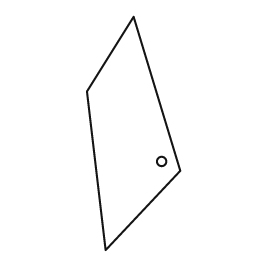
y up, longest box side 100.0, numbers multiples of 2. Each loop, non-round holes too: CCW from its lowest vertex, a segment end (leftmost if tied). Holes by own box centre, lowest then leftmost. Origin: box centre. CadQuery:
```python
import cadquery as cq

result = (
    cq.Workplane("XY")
    .moveTo(-12.0, -50.0)
    .lineTo(20.0, -16.0)
    .lineTo(0.0, 50.0)
    .lineTo(-20.0, 18.0)
    .close()
    .moveTo(12.0, -12.0)
    .circle(2.0)
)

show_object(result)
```